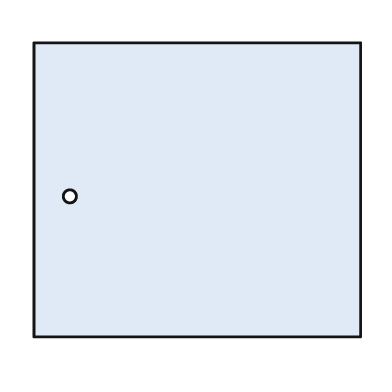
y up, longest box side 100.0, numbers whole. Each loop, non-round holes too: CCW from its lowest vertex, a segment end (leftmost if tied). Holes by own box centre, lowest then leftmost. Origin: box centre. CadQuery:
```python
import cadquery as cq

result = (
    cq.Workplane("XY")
    .moveTo(-50.0, -45.0)
    .lineTo(50.0, -45.0)
    .lineTo(50.0, 45.0)
    .lineTo(-50.0, 45.0)
    .close()
    .moveTo(-39.0, -2.0)
    .circle(2.0)
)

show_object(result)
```